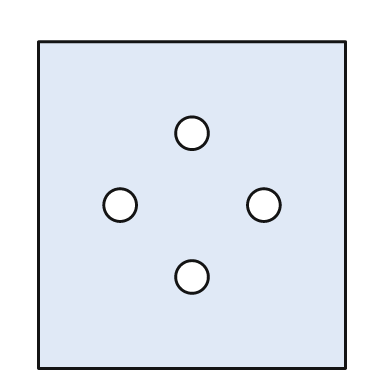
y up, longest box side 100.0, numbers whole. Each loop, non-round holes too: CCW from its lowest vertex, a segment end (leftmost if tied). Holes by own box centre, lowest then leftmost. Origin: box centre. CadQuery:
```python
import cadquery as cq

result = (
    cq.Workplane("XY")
    .moveTo(-47.0, -50.0)
    .lineTo(47.0, -50.0)
    .lineTo(47.0, 50.0)
    .lineTo(-47.0, 50.0)
    .close()
    .moveTo(0.0, -22.0)
    .circle(5.0)
    .moveTo(-22.0, 0.0)
    .circle(5.0)
    .moveTo(22.0, 0.0)
    .circle(5.0)
    .moveTo(0.0, 22.0)
    .circle(5.0)
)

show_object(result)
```